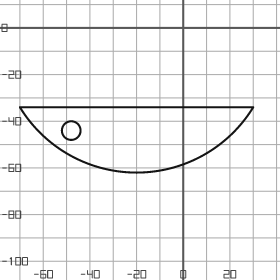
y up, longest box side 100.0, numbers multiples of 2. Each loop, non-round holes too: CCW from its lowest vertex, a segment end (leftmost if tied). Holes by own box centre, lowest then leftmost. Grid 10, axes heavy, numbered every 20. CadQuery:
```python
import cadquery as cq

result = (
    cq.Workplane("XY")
    .moveTo(-70.0, -34.0)
    .threePointArc((-20.0, -62.0), (30.0, -34.0))
    .close()
    .moveTo(-48.0, -44.0)
    .circle(4.0)
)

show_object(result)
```